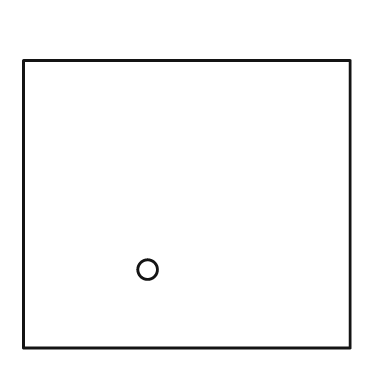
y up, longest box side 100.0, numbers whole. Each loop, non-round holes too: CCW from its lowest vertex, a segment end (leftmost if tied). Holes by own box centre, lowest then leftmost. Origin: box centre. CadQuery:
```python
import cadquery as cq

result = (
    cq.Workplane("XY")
    .moveTo(-50.0, -44.0)
    .lineTo(50.0, -44.0)
    .lineTo(50.0, 44.0)
    .lineTo(-50.0, 44.0)
    .close()
    .moveTo(-12.0, -20.0)
    .circle(3.0)
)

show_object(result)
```